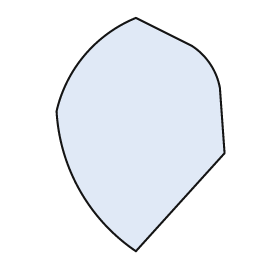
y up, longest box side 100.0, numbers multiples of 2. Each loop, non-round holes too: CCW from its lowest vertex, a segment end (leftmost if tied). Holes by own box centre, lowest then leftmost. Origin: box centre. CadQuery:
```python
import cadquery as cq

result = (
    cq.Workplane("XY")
    .moveTo(-2.0, -50.0)
    .lineTo(36.0, -8.0)
    .lineTo(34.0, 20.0)
    .threePointArc((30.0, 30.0), (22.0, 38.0))
    .lineTo(-2.0, 50.0)
    .threePointArc((-24.0, 34.0), (-36.0, 10.0))
    .threePointArc((-26.0, -24.0), (-2.0, -50.0))
    .close()
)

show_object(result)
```